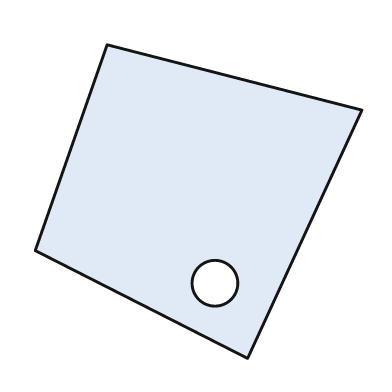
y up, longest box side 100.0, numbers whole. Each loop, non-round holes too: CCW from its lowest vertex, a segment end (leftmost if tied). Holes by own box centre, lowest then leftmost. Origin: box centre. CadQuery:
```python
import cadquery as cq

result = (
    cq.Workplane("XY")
    .moveTo(15.0, -48.0)
    .lineTo(50.0, 28.0)
    .lineTo(-28.0, 48.0)
    .lineTo(-50.0, -15.0)
    .close()
    .moveTo(5.0, -25.0)
    .circle(7.0)
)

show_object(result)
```